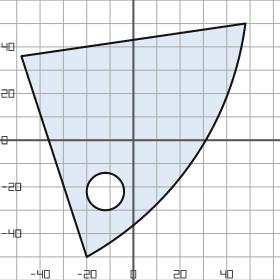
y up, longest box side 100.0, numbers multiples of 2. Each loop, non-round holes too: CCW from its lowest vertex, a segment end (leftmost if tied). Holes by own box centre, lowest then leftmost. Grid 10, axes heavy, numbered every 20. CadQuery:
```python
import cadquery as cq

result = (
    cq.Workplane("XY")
    .moveTo(-20.0, -50.0)
    .threePointArc((26.0, -8.0), (48.0, 50.0))
    .lineTo(-48.0, 36.0)
    .close()
    .moveTo(-12.0, -22.0)
    .circle(8.0)
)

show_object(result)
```